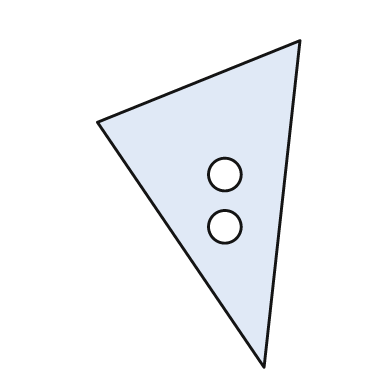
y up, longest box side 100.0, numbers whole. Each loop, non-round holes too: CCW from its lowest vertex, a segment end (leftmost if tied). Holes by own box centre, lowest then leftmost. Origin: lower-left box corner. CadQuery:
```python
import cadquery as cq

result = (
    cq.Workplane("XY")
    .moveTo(51.0, 0.0)
    .lineTo(62.0, 100.0)
    .lineTo(0.0, 75.0)
    .close()
    .moveTo(39.0, 43.0)
    .circle(5.0)
    .moveTo(39.0, 59.0)
    .circle(5.0)
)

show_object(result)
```